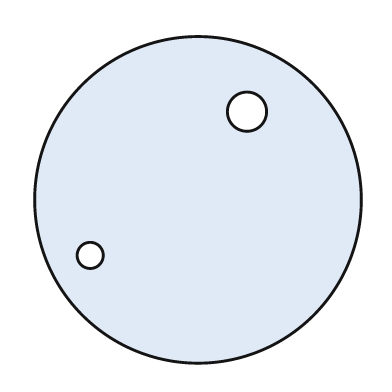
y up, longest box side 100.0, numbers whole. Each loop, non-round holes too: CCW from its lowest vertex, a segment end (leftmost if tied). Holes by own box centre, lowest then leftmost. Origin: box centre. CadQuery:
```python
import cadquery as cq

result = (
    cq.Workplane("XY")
    .moveTo(0.0, 0.0)
    .circle(50.0)
    .moveTo(-33.0, -17.0)
    .circle(4.0)
    .moveTo(15.0, 27.0)
    .circle(6.0)
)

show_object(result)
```